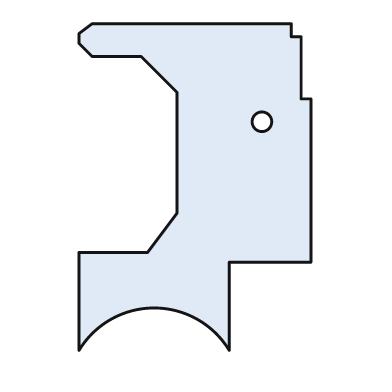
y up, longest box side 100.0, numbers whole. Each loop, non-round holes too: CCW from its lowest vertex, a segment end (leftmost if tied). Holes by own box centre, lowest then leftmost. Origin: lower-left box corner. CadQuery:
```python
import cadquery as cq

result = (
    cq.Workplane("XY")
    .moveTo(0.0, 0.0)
    .threePointArc((23.0, 13.0), (46.0, 0.0))
    .lineTo(46.0, 27.0)
    .lineTo(71.0, 27.0)
    .lineTo(71.0, 77.0)
    .lineTo(68.0, 77.0)
    .lineTo(68.0, 96.0)
    .lineTo(65.0, 96.0)
    .lineTo(65.0, 100.0)
    .lineTo(4.0, 100.0)
    .lineTo(0.0, 97.0)
    .lineTo(0.0, 94.0)
    .lineTo(4.0, 90.0)
    .lineTo(19.0, 90.0)
    .lineTo(30.0, 79.0)
    .lineTo(30.0, 42.0)
    .lineTo(21.0, 30.0)
    .lineTo(0.0, 30.0)
    .close()
    .moveTo(56.0, 70.0)
    .circle(3.0)
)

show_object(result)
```